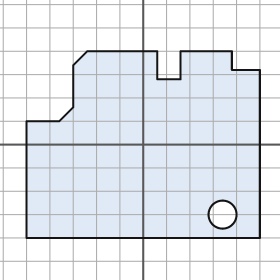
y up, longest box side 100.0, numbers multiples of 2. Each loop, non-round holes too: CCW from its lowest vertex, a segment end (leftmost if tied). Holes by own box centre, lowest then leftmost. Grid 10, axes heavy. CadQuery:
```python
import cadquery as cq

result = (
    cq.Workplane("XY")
    .moveTo(-50.0, -40.0)
    .lineTo(50.0, -40.0)
    .lineTo(50.0, 32.0)
    .lineTo(38.0, 32.0)
    .lineTo(38.0, 40.0)
    .lineTo(16.0, 40.0)
    .lineTo(16.0, 28.0)
    .lineTo(6.0, 28.0)
    .lineTo(6.0, 40.0)
    .lineTo(-24.0, 40.0)
    .lineTo(-30.0, 34.0)
    .lineTo(-30.0, 16.0)
    .lineTo(-36.0, 10.0)
    .lineTo(-50.0, 10.0)
    .close()
    .moveTo(34.0, -30.0)
    .circle(6.0)
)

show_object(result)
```